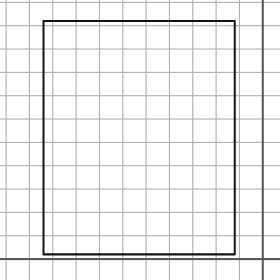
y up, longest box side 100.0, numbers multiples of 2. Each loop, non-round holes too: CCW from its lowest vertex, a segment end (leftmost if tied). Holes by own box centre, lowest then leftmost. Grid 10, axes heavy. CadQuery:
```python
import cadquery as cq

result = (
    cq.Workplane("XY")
    .moveTo(-94.0, 2.0)
    .lineTo(-12.0, 2.0)
    .lineTo(-12.0, 102.0)
    .lineTo(-94.0, 102.0)
    .close()
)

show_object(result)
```